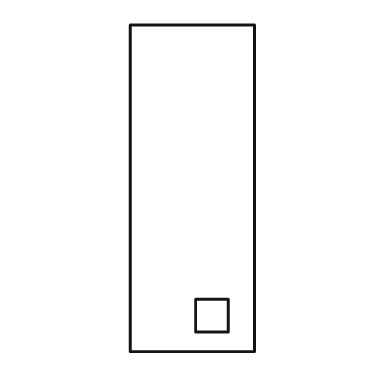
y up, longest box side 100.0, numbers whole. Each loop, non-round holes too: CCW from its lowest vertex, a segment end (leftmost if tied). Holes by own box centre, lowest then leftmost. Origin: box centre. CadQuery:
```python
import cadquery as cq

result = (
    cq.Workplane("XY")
    .moveTo(-19.0, -50.0)
    .lineTo(19.0, -50.0)
    .lineTo(19.0, 50.0)
    .lineTo(-19.0, 50.0)
    .close()
    .moveTo(1.0, -44.0)
    .lineTo(11.0, -44.0)
    .lineTo(11.0, -34.0)
    .lineTo(1.0, -34.0)
    .close()
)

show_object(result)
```